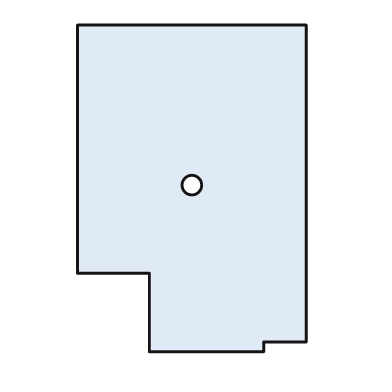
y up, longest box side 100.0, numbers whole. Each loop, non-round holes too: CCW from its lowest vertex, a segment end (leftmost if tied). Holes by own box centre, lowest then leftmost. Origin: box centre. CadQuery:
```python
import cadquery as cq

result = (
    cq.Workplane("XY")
    .moveTo(-13.0, -50.0)
    .lineTo(22.0, -50.0)
    .lineTo(22.0, -47.0)
    .lineTo(35.0, -47.0)
    .lineTo(35.0, 50.0)
    .lineTo(-35.0, 50.0)
    .lineTo(-35.0, -26.0)
    .lineTo(-13.0, -26.0)
    .close()
    .moveTo(0.0, 1.0)
    .circle(3.0)
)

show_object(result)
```